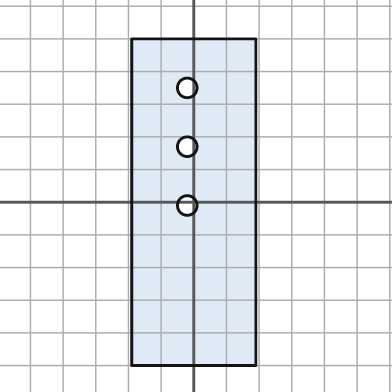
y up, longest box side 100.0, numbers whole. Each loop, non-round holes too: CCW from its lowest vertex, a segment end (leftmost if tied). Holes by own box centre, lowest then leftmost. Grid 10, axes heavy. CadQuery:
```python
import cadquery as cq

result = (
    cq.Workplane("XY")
    .moveTo(-19.0, -50.0)
    .lineTo(19.0, -50.0)
    .lineTo(19.0, 50.0)
    .lineTo(-19.0, 50.0)
    .close()
    .moveTo(-2.0, -1.0)
    .circle(3.0)
    .moveTo(-2.0, 17.0)
    .circle(3.0)
    .moveTo(-2.0, 35.0)
    .circle(3.0)
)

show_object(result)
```